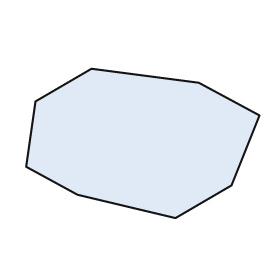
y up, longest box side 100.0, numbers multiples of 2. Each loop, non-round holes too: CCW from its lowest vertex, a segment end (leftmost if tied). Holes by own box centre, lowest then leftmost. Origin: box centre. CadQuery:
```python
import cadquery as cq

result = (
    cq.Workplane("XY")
    .moveTo(14.0, -32.0)
    .lineTo(38.0, -18.0)
    .lineTo(50.0, 12.0)
    .lineTo(24.0, 26.0)
    .lineTo(-22.0, 32.0)
    .lineTo(-46.0, 18.0)
    .lineTo(-50.0, -10.0)
    .lineTo(-28.0, -22.0)
    .close()
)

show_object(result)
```